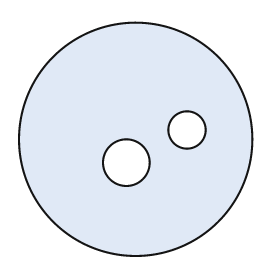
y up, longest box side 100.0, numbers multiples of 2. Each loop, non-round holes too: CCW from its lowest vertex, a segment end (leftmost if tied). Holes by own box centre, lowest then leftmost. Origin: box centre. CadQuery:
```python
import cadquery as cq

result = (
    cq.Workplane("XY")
    .moveTo(0.0, 0.0)
    .circle(50.0)
    .moveTo(-4.0, -10.0)
    .circle(10.0)
    .moveTo(22.0, 4.0)
    .circle(8.0)
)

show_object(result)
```